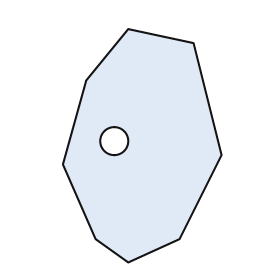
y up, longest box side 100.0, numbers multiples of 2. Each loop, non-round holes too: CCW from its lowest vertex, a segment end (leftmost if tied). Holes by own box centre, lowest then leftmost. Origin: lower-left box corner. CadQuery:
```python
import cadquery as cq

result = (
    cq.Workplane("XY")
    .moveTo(28.0, 0.0)
    .lineTo(50.0, 10.0)
    .lineTo(68.0, 46.0)
    .lineTo(56.0, 94.0)
    .lineTo(28.0, 100.0)
    .lineTo(10.0, 78.0)
    .lineTo(0.0, 42.0)
    .lineTo(14.0, 10.0)
    .close()
    .moveTo(22.0, 52.0)
    .circle(6.0)
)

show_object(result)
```